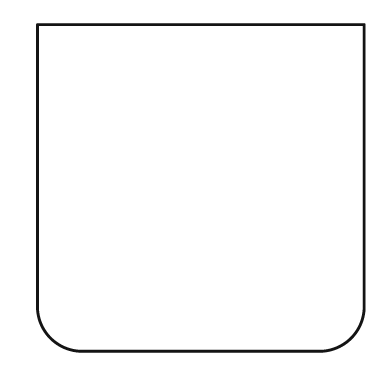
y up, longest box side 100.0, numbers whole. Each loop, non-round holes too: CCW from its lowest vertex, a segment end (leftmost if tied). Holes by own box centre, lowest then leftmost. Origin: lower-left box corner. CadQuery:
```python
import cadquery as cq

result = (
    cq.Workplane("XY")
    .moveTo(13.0, 0.0)
    .lineTo(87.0, 0.0)
    .threePointArc((96.0, 4.0), (100.0, 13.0))
    .lineTo(100.0, 100.0)
    .lineTo(0.0, 100.0)
    .lineTo(0.0, 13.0)
    .threePointArc((4.0, 4.0), (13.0, 0.0))
    .close()
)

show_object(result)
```